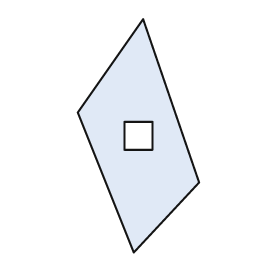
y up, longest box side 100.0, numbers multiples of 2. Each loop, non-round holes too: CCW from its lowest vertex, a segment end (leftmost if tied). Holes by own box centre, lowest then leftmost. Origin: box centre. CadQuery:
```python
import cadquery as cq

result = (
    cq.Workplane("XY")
    .moveTo(-2.0, -50.0)
    .lineTo(26.0, -20.0)
    .lineTo(2.0, 50.0)
    .lineTo(-26.0, 10.0)
    .close()
    .moveTo(-6.0, -6.0)
    .lineTo(6.0, -6.0)
    .lineTo(6.0, 6.0)
    .lineTo(-6.0, 6.0)
    .close()
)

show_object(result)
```